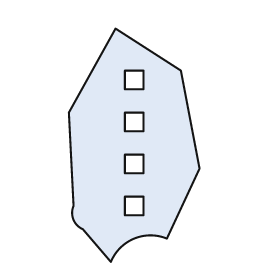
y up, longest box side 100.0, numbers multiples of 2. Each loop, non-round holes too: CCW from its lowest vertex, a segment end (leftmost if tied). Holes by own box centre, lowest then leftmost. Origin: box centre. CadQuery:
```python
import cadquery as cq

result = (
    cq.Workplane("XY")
    .moveTo(-10.0, -50.0)
    .threePointArc((0.0, -40.0), (14.0, -40.0))
    .lineTo(28.0, -10.0)
    .lineTo(20.0, 32.0)
    .lineTo(-8.0, 50.0)
    .lineTo(-28.0, 14.0)
    .lineTo(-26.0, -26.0)
    .threePointArc((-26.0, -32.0), (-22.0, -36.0))
    .close()
    .moveTo(-4.0, -30.0)
    .lineTo(4.0, -30.0)
    .lineTo(4.0, -22.0)
    .lineTo(-4.0, -22.0)
    .close()
    .moveTo(-4.0, -12.0)
    .lineTo(4.0, -12.0)
    .lineTo(4.0, -4.0)
    .lineTo(-4.0, -4.0)
    .close()
    .moveTo(-4.0, 6.0)
    .lineTo(4.0, 6.0)
    .lineTo(4.0, 14.0)
    .lineTo(-4.0, 14.0)
    .close()
    .moveTo(-4.0, 24.0)
    .lineTo(4.0, 24.0)
    .lineTo(4.0, 32.0)
    .lineTo(-4.0, 32.0)
    .close()
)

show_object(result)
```